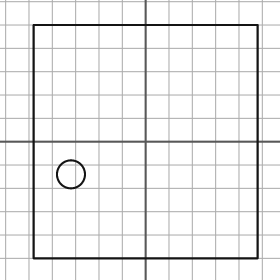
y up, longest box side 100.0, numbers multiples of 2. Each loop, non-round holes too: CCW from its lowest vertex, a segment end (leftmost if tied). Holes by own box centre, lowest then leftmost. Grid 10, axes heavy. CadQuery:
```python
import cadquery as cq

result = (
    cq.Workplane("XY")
    .moveTo(-48.0, -50.0)
    .lineTo(48.0, -50.0)
    .lineTo(48.0, 50.0)
    .lineTo(-48.0, 50.0)
    .close()
    .moveTo(-32.0, -14.0)
    .circle(6.0)
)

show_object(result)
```